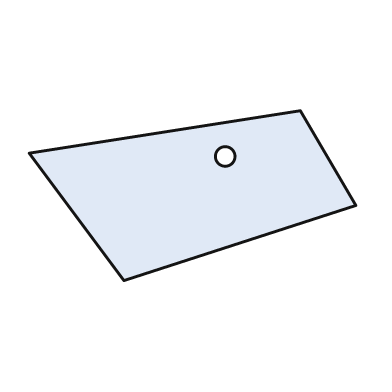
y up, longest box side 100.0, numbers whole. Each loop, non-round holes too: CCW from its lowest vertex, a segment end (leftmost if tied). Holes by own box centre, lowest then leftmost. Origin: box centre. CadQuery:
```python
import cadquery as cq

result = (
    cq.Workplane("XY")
    .moveTo(-21.0, -26.0)
    .lineTo(50.0, -3.0)
    .lineTo(33.0, 26.0)
    .lineTo(-50.0, 13.0)
    .close()
    .moveTo(10.0, 12.0)
    .circle(3.0)
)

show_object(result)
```